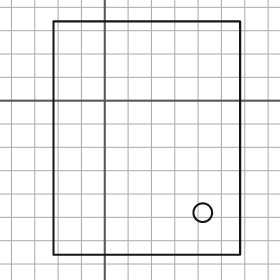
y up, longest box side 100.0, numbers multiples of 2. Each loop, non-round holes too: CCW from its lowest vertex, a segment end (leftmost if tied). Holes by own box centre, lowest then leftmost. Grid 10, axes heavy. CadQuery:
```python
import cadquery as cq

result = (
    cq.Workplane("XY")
    .moveTo(-22.0, -66.0)
    .lineTo(58.0, -66.0)
    .lineTo(58.0, 34.0)
    .lineTo(-22.0, 34.0)
    .close()
    .moveTo(42.0, -48.0)
    .circle(4.0)
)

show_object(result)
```